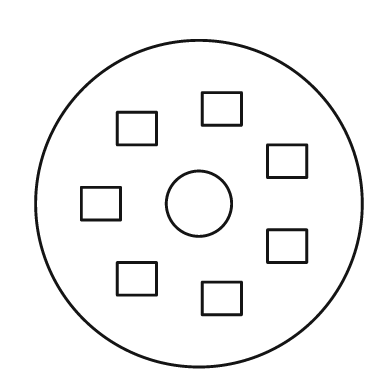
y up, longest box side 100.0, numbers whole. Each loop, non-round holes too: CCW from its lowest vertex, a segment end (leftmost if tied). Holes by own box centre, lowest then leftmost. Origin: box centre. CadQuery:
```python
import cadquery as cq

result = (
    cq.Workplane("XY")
    .moveTo(0.0, 0.0)
    .circle(50.0)
    .moveTo(1.0, -34.0)
    .lineTo(13.0, -34.0)
    .lineTo(13.0, -24.0)
    .lineTo(1.0, -24.0)
    .close()
    .moveTo(-25.0, -28.0)
    .lineTo(-13.0, -28.0)
    .lineTo(-13.0, -18.0)
    .lineTo(-25.0, -18.0)
    .close()
    .moveTo(21.0, -18.0)
    .lineTo(33.0, -18.0)
    .lineTo(33.0, -8.0)
    .lineTo(21.0, -8.0)
    .close()
    .moveTo(-36.0, -5.0)
    .lineTo(-24.0, -5.0)
    .lineTo(-24.0, 5.0)
    .lineTo(-36.0, 5.0)
    .close()
    .moveTo(0.0, 0.0)
    .circle(10.0)
    .moveTo(21.0, 8.0)
    .lineTo(33.0, 8.0)
    .lineTo(33.0, 18.0)
    .lineTo(21.0, 18.0)
    .close()
    .moveTo(-25.0, 18.0)
    .lineTo(-13.0, 18.0)
    .lineTo(-13.0, 28.0)
    .lineTo(-25.0, 28.0)
    .close()
    .moveTo(1.0, 24.0)
    .lineTo(13.0, 24.0)
    .lineTo(13.0, 34.0)
    .lineTo(1.0, 34.0)
    .close()
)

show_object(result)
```